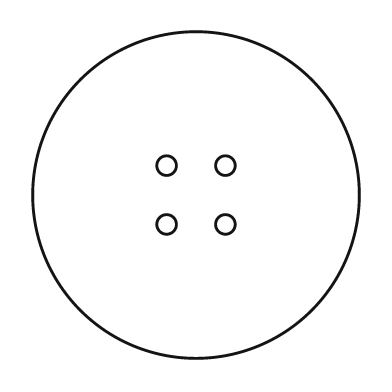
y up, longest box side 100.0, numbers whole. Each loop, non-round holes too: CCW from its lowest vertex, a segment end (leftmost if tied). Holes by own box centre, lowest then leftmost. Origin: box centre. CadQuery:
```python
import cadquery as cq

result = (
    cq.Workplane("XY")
    .moveTo(0.0, 0.0)
    .circle(50.0)
    .moveTo(-9.0, -9.0)
    .circle(3.0)
    .moveTo(9.0, -9.0)
    .circle(3.0)
    .moveTo(-9.0, 9.0)
    .circle(3.0)
    .moveTo(9.0, 9.0)
    .circle(3.0)
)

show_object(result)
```